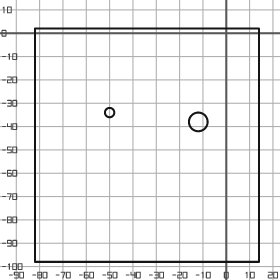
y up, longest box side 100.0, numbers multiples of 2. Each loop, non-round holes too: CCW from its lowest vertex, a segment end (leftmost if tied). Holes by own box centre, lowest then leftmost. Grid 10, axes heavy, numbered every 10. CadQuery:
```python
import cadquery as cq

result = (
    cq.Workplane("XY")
    .moveTo(-82.0, -98.0)
    .lineTo(14.0, -98.0)
    .lineTo(14.0, 2.0)
    .lineTo(-82.0, 2.0)
    .close()
    .moveTo(-12.0, -38.0)
    .circle(4.0)
    .moveTo(-50.0, -34.0)
    .circle(2.0)
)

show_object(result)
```